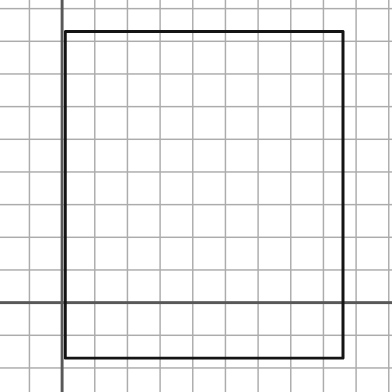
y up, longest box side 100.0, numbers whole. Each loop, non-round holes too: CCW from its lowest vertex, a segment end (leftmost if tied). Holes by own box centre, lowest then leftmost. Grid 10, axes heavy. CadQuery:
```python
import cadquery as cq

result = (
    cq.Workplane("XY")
    .moveTo(1.0, -17.0)
    .lineTo(86.0, -17.0)
    .lineTo(86.0, 83.0)
    .lineTo(1.0, 83.0)
    .close()
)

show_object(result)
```